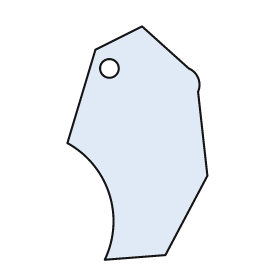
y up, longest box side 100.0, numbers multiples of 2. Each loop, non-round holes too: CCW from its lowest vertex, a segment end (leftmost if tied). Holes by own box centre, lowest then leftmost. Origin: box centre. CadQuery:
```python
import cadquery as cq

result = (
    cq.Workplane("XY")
    .moveTo(-14.0, -50.0)
    .lineTo(12.0, -48.0)
    .lineTo(30.0, -14.0)
    .lineTo(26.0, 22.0)
    .threePointArc((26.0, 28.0), (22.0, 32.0))
    .lineTo(2.0, 50.0)
    .lineTo(-18.0, 40.0)
    .lineTo(-30.0, 0.0)
    .threePointArc((-12.0, -22.0), (-14.0, -50.0))
    .close()
    .moveTo(-12.0, 32.0)
    .circle(4.0)
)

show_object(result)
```